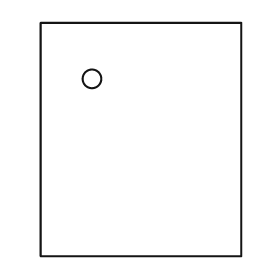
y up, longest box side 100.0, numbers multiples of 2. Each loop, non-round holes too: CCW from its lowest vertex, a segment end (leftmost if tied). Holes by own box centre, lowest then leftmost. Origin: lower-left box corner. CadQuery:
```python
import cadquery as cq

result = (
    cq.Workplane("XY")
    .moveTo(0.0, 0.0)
    .lineTo(86.0, 0.0)
    .lineTo(86.0, 100.0)
    .lineTo(0.0, 100.0)
    .close()
    .moveTo(22.0, 76.0)
    .circle(4.0)
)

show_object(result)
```